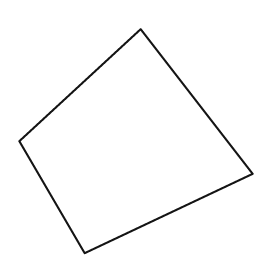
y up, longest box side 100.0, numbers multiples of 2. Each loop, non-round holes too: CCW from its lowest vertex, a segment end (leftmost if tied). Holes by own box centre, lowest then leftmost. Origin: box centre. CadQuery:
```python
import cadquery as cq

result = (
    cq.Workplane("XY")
    .moveTo(-22.0, -48.0)
    .lineTo(50.0, -14.0)
    .lineTo(2.0, 48.0)
    .lineTo(-50.0, 0.0)
    .close()
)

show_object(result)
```